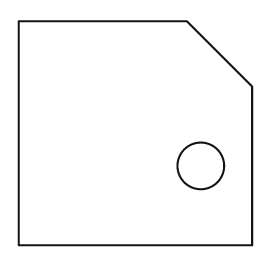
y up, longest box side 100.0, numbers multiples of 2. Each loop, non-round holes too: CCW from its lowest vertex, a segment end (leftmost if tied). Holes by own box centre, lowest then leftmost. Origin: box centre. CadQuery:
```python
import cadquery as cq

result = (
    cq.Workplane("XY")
    .moveTo(-50.0, -48.0)
    .lineTo(50.0, -48.0)
    .lineTo(50.0, 20.0)
    .lineTo(22.0, 48.0)
    .lineTo(-50.0, 48.0)
    .close()
    .moveTo(28.0, -14.0)
    .circle(10.0)
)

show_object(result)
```